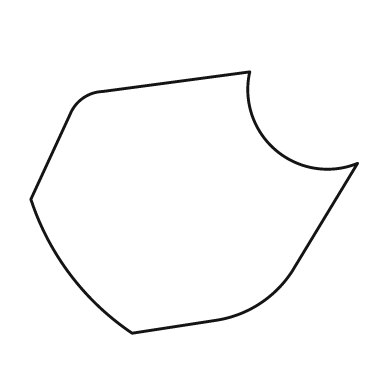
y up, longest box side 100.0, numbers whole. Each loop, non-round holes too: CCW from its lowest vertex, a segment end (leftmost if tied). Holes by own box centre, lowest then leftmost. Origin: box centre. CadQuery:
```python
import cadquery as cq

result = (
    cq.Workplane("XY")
    .moveTo(-19.0, -40.0)
    .lineTo(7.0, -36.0)
    .threePointArc((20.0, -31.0), (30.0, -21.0))
    .lineTo(50.0, 12.0)
    .threePointArc((25.0, 16.0), (17.0, 40.0))
    .lineTo(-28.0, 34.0)
    .threePointArc((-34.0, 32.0), (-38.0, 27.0))
    .lineTo(-50.0, 1.0)
    .threePointArc((-38.0, -22.0), (-19.0, -40.0))
    .close()
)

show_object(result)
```